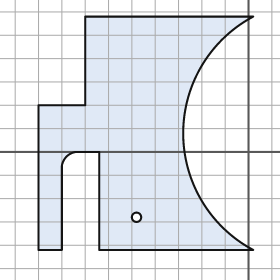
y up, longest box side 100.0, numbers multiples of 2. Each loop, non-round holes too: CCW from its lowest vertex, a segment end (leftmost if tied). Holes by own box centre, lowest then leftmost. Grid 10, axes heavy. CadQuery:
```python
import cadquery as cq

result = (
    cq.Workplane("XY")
    .moveTo(-90.0, -42.0)
    .lineTo(-80.0, -42.0)
    .lineTo(-80.0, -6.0)
    .threePointArc((-78.0, -2.0), (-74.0, 0.0))
    .lineTo(-64.0, 0.0)
    .lineTo(-64.0, -42.0)
    .lineTo(2.0, -42.0)
    .threePointArc((-28.0, 8.0), (2.0, 58.0))
    .lineTo(-70.0, 58.0)
    .lineTo(-70.0, 20.0)
    .lineTo(-90.0, 20.0)
    .close()
    .moveTo(-48.0, -28.0)
    .circle(2.0)
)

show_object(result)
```